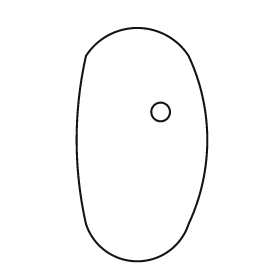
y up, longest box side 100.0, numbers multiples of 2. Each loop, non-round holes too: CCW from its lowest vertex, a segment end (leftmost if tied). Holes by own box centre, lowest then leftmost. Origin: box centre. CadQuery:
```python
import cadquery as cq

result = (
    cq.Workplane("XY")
    .moveTo(-24.0, -34.0)
    .threePointArc((-2.0, -50.0), (20.0, -34.0))
    .threePointArc((28.0, 2.0), (20.0, 38.0))
    .threePointArc((-2.0, 50.0), (-24.0, 38.0))
    .threePointArc((-28.0, 2.0), (-24.0, -34.0))
    .close()
    .moveTo(8.0, 14.0)
    .circle(4.0)
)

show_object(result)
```